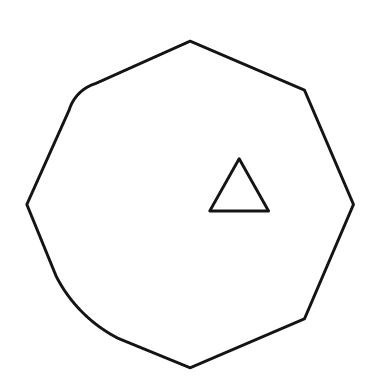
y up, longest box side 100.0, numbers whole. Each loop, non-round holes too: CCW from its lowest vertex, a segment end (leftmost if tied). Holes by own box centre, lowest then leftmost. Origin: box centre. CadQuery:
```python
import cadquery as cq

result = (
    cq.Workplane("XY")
    .moveTo(0.0, -50.0)
    .lineTo(35.0, -35.0)
    .lineTo(50.0, 0.0)
    .lineTo(35.0, 35.0)
    .lineTo(0.0, 50.0)
    .lineTo(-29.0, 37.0)
    .threePointArc((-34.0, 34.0), (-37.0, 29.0))
    .lineTo(-50.0, 0.0)
    .lineTo(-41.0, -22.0)
    .threePointArc((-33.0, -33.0), (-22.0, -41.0))
    .close()
    .moveTo(6.0, -2.0)
    .lineTo(24.0, -2.0)
    .lineTo(15.0, 14.0)
    .close()
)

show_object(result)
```